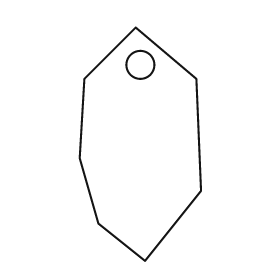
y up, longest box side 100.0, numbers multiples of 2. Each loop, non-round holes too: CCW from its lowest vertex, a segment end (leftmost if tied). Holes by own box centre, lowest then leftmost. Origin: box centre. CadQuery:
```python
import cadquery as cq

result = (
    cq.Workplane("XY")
    .moveTo(2.0, -50.0)
    .lineTo(26.0, -20.0)
    .lineTo(24.0, 28.0)
    .lineTo(-2.0, 50.0)
    .lineTo(-24.0, 28.0)
    .lineTo(-26.0, -6.0)
    .lineTo(-18.0, -34.0)
    .close()
    .moveTo(0.0, 34.0)
    .circle(6.0)
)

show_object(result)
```